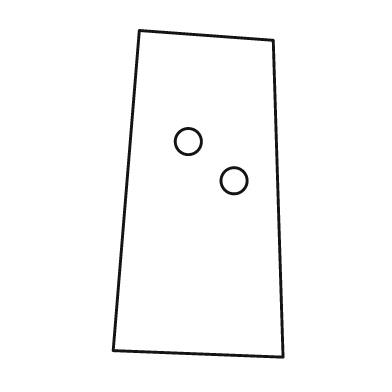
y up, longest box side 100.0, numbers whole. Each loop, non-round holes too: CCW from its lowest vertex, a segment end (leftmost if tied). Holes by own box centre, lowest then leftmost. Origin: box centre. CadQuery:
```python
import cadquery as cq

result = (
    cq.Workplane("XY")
    .moveTo(26.0, -50.0)
    .lineTo(23.0, 47.0)
    .lineTo(-18.0, 50.0)
    .lineTo(-26.0, -48.0)
    .close()
    .moveTo(11.0, 4.0)
    .circle(4.0)
    .moveTo(-3.0, 16.0)
    .circle(4.0)
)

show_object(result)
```